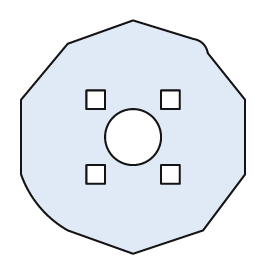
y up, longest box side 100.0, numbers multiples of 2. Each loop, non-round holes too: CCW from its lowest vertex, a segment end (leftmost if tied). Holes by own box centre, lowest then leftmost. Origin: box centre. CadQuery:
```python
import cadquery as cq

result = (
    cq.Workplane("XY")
    .moveTo(0.0, -50.0)
    .lineTo(30.0, -40.0)
    .lineTo(48.0, -16.0)
    .lineTo(48.0, 16.0)
    .lineTo(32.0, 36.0)
    .threePointArc((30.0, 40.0), (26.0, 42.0))
    .lineTo(0.0, 50.0)
    .lineTo(-28.0, 40.0)
    .lineTo(-48.0, 16.0)
    .lineTo(-48.0, -16.0)
    .threePointArc((-40.0, -30.0), (-28.0, -40.0))
    .close()
    .moveTo(-20.0, -20.0)
    .lineTo(-12.0, -20.0)
    .lineTo(-12.0, -12.0)
    .lineTo(-20.0, -12.0)
    .close()
    .moveTo(12.0, -20.0)
    .lineTo(20.0, -20.0)
    .lineTo(20.0, -12.0)
    .lineTo(12.0, -12.0)
    .close()
    .moveTo(0.0, 0.0)
    .circle(12.0)
    .moveTo(-20.0, 12.0)
    .lineTo(-12.0, 12.0)
    .lineTo(-12.0, 20.0)
    .lineTo(-20.0, 20.0)
    .close()
    .moveTo(12.0, 12.0)
    .lineTo(20.0, 12.0)
    .lineTo(20.0, 20.0)
    .lineTo(12.0, 20.0)
    .close()
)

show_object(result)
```